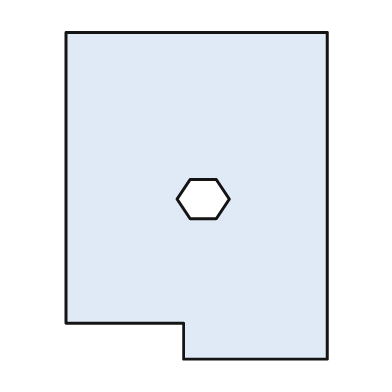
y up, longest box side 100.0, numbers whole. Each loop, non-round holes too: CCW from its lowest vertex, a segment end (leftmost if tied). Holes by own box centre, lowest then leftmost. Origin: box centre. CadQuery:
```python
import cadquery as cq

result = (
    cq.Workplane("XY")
    .moveTo(-4.0, -50.0)
    .lineTo(40.0, -50.0)
    .lineTo(40.0, 50.0)
    .lineTo(-40.0, 50.0)
    .lineTo(-40.0, -39.0)
    .lineTo(-4.0, -39.0)
    .close()
    .moveTo(-2.0, -7.0)
    .lineTo(6.0, -7.0)
    .lineTo(10.0, -1.0)
    .lineTo(6.0, 5.0)
    .lineTo(-2.0, 5.0)
    .lineTo(-6.0, -1.0)
    .close()
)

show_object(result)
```